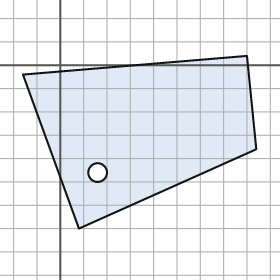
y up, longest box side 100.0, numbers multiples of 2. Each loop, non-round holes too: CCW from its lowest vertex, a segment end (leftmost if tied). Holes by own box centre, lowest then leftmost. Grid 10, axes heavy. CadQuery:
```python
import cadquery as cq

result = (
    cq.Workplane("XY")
    .moveTo(8.0, -70.0)
    .lineTo(84.0, -36.0)
    .lineTo(80.0, 4.0)
    .lineTo(-16.0, -4.0)
    .close()
    .moveTo(16.0, -46.0)
    .circle(4.0)
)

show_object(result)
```